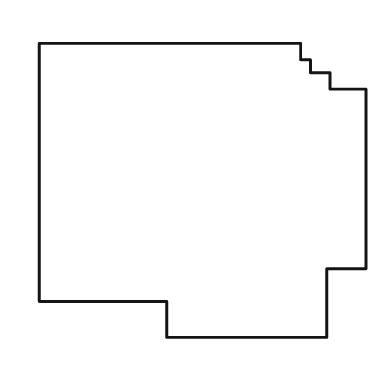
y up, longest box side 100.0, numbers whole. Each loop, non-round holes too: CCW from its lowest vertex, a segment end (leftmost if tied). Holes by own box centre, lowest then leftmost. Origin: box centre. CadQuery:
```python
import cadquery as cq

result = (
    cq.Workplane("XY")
    .moveTo(-11.0, -45.0)
    .lineTo(38.0, -45.0)
    .lineTo(38.0, -24.0)
    .lineTo(50.0, -24.0)
    .lineTo(50.0, 31.0)
    .lineTo(39.0, 31.0)
    .lineTo(39.0, 36.0)
    .lineTo(33.0, 36.0)
    .lineTo(33.0, 40.0)
    .lineTo(30.0, 40.0)
    .lineTo(30.0, 45.0)
    .lineTo(-50.0, 45.0)
    .lineTo(-50.0, -34.0)
    .lineTo(-11.0, -34.0)
    .close()
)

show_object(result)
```